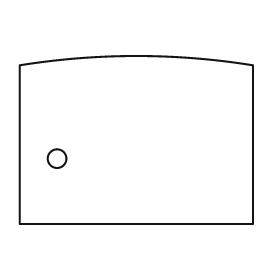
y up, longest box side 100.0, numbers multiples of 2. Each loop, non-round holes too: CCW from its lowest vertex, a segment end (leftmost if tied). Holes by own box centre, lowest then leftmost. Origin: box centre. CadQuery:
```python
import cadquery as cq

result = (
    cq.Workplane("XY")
    .moveTo(-50.0, -36.0)
    .lineTo(50.0, -36.0)
    .lineTo(50.0, 32.0)
    .threePointArc((0.0, 36.0), (-50.0, 32.0))
    .close()
    .moveTo(-34.0, -8.0)
    .circle(4.0)
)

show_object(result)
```